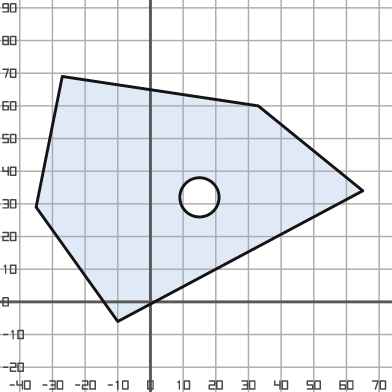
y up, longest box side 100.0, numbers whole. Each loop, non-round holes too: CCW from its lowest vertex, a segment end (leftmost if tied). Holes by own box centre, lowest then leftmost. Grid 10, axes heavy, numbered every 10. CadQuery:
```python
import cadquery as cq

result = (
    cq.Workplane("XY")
    .moveTo(-10.0, -6.0)
    .lineTo(65.0, 34.0)
    .lineTo(33.0, 60.0)
    .lineTo(-27.0, 69.0)
    .lineTo(-35.0, 29.0)
    .close()
    .moveTo(15.0, 32.0)
    .circle(6.0)
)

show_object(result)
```